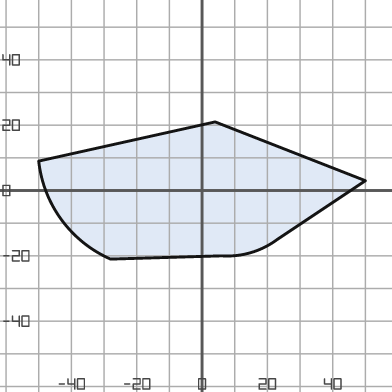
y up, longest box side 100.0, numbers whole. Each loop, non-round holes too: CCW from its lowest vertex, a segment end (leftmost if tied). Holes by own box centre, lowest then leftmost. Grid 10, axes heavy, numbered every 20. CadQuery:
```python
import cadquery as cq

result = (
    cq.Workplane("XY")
    .moveTo(-28.0, -21.0)
    .lineTo(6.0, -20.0)
    .threePointArc((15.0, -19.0), (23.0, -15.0))
    .lineTo(50.0, 3.0)
    .lineTo(4.0, 21.0)
    .lineTo(-50.0, 9.0)
    .threePointArc((-43.0, -9.0), (-28.0, -21.0))
    .close()
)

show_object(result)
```